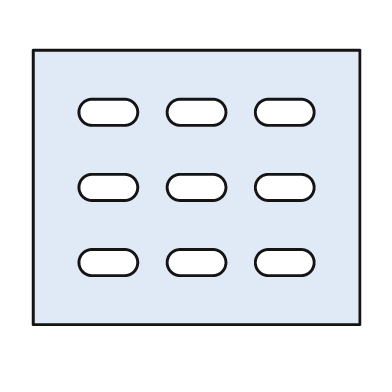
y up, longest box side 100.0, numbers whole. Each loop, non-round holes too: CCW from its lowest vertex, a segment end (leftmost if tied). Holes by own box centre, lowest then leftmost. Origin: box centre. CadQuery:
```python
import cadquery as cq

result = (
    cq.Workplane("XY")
    .moveTo(-50.0, -42.0)
    .lineTo(50.0, -42.0)
    .lineTo(50.0, 42.0)
    .lineTo(-50.0, 42.0)
    .close()
    .moveTo(-32.0, -27.0)
    .lineTo(-22.0, -27.0)
    .threePointArc((-18.0, -23.0), (-22.0, -19.0))
    .lineTo(-32.0, -19.0)
    .threePointArc((-36.0, -23.0), (-32.0, -27.0))
    .close()
    .moveTo(-5.0, -27.0)
    .lineTo(5.0, -27.0)
    .threePointArc((9.0, -23.0), (5.0, -19.0))
    .lineTo(-5.0, -19.0)
    .threePointArc((-9.0, -23.0), (-5.0, -27.0))
    .close()
    .moveTo(22.0, -27.0)
    .lineTo(32.0, -27.0)
    .threePointArc((36.0, -23.0), (32.0, -19.0))
    .lineTo(22.0, -19.0)
    .threePointArc((18.0, -23.0), (22.0, -27.0))
    .close()
    .moveTo(-32.0, -4.0)
    .lineTo(-22.0, -4.0)
    .threePointArc((-18.0, 0.0), (-22.0, 4.0))
    .lineTo(-32.0, 4.0)
    .threePointArc((-36.0, 0.0), (-32.0, -4.0))
    .close()
    .moveTo(-5.0, -4.0)
    .lineTo(5.0, -4.0)
    .threePointArc((9.0, 0.0), (5.0, 4.0))
    .lineTo(-5.0, 4.0)
    .threePointArc((-9.0, 0.0), (-5.0, -4.0))
    .close()
    .moveTo(22.0, -4.0)
    .lineTo(32.0, -4.0)
    .threePointArc((36.0, 0.0), (32.0, 4.0))
    .lineTo(22.0, 4.0)
    .threePointArc((18.0, 0.0), (22.0, -4.0))
    .close()
    .moveTo(-32.0, 19.0)
    .lineTo(-22.0, 19.0)
    .threePointArc((-18.0, 23.0), (-22.0, 27.0))
    .lineTo(-32.0, 27.0)
    .threePointArc((-36.0, 23.0), (-32.0, 19.0))
    .close()
    .moveTo(-5.0, 19.0)
    .lineTo(5.0, 19.0)
    .threePointArc((9.0, 23.0), (5.0, 27.0))
    .lineTo(-5.0, 27.0)
    .threePointArc((-9.0, 23.0), (-5.0, 19.0))
    .close()
    .moveTo(22.0, 19.0)
    .lineTo(32.0, 19.0)
    .threePointArc((36.0, 23.0), (32.0, 27.0))
    .lineTo(22.0, 27.0)
    .threePointArc((18.0, 23.0), (22.0, 19.0))
    .close()
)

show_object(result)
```